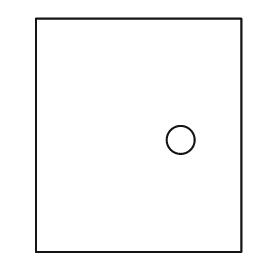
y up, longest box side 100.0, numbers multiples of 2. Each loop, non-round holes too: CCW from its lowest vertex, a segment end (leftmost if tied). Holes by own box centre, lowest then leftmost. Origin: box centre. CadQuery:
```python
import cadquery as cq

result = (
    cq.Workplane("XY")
    .moveTo(-44.0, -50.0)
    .lineTo(44.0, -50.0)
    .lineTo(44.0, 50.0)
    .lineTo(-44.0, 50.0)
    .close()
    .moveTo(18.0, -2.0)
    .circle(6.0)
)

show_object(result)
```